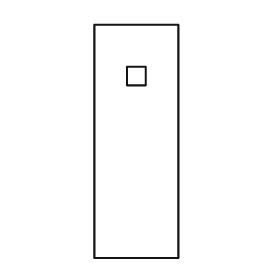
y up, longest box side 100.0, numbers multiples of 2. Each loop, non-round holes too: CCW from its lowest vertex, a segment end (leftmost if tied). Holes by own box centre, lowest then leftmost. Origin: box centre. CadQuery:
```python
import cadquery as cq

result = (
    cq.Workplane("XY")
    .moveTo(-18.0, -50.0)
    .lineTo(18.0, -50.0)
    .lineTo(18.0, 50.0)
    .lineTo(-18.0, 50.0)
    .close()
    .moveTo(-4.0, 24.0)
    .lineTo(4.0, 24.0)
    .lineTo(4.0, 32.0)
    .lineTo(-4.0, 32.0)
    .close()
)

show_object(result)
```